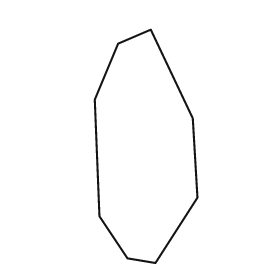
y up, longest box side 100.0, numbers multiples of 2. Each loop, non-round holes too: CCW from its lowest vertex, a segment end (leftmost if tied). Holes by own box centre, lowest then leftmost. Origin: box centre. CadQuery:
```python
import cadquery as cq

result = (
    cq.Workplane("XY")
    .moveTo(4.0, -50.0)
    .lineTo(22.0, -22.0)
    .lineTo(20.0, 12.0)
    .lineTo(2.0, 50.0)
    .lineTo(-12.0, 44.0)
    .lineTo(-22.0, 20.0)
    .lineTo(-20.0, -30.0)
    .lineTo(-8.0, -48.0)
    .close()
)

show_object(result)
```